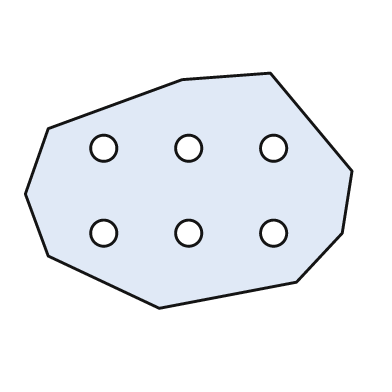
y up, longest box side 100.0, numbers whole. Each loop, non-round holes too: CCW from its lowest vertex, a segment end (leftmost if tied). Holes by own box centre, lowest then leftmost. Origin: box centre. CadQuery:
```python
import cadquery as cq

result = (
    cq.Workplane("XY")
    .moveTo(-9.0, -36.0)
    .lineTo(33.0, -28.0)
    .lineTo(47.0, -13.0)
    .lineTo(50.0, 6.0)
    .lineTo(25.0, 36.0)
    .lineTo(-2.0, 34.0)
    .lineTo(-43.0, 19.0)
    .lineTo(-50.0, -1.0)
    .lineTo(-43.0, -20.0)
    .close()
    .moveTo(-26.0, -13.0)
    .circle(4.0)
    .moveTo(0.0, -13.0)
    .circle(4.0)
    .moveTo(26.0, -13.0)
    .circle(4.0)
    .moveTo(-26.0, 13.0)
    .circle(4.0)
    .moveTo(0.0, 13.0)
    .circle(4.0)
    .moveTo(26.0, 13.0)
    .circle(4.0)
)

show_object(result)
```